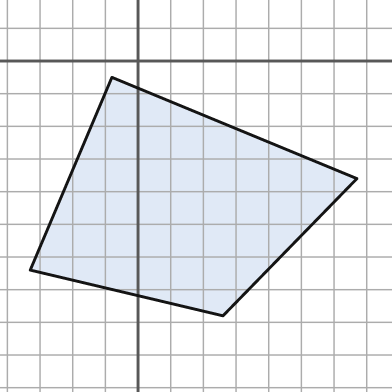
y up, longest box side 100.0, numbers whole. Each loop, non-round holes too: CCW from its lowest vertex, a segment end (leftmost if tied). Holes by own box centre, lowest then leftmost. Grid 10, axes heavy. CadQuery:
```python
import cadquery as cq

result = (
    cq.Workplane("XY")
    .moveTo(26.0, -78.0)
    .lineTo(67.0, -36.0)
    .lineTo(-8.0, -5.0)
    .lineTo(-33.0, -64.0)
    .close()
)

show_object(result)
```